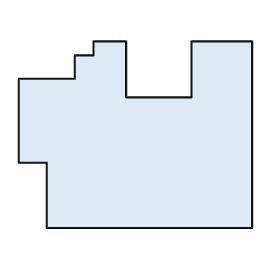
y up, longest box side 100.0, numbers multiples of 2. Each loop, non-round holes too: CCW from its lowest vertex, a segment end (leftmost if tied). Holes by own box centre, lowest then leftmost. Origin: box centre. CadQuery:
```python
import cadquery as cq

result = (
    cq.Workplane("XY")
    .moveTo(-38.0, -40.0)
    .lineTo(50.0, -40.0)
    .lineTo(50.0, 40.0)
    .lineTo(24.0, 40.0)
    .lineTo(24.0, 16.0)
    .lineTo(-4.0, 16.0)
    .lineTo(-4.0, 40.0)
    .lineTo(-18.0, 40.0)
    .lineTo(-18.0, 34.0)
    .lineTo(-26.0, 34.0)
    .lineTo(-26.0, 24.0)
    .lineTo(-50.0, 24.0)
    .lineTo(-50.0, -12.0)
    .lineTo(-38.0, -12.0)
    .close()
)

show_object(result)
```